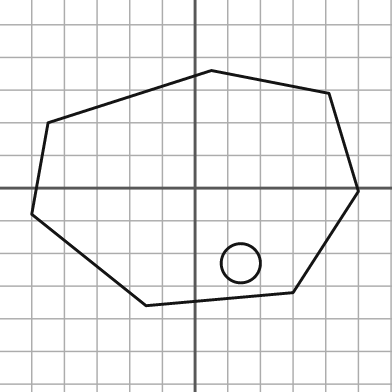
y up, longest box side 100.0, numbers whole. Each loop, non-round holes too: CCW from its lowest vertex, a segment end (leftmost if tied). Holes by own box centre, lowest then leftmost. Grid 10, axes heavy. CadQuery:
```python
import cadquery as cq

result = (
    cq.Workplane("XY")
    .moveTo(-15.0, -36.0)
    .lineTo(30.0, -32.0)
    .lineTo(50.0, -1.0)
    .lineTo(41.0, 29.0)
    .lineTo(5.0, 36.0)
    .lineTo(-45.0, 20.0)
    .lineTo(-50.0, -8.0)
    .close()
    .moveTo(14.0, -23.0)
    .circle(6.0)
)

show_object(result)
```